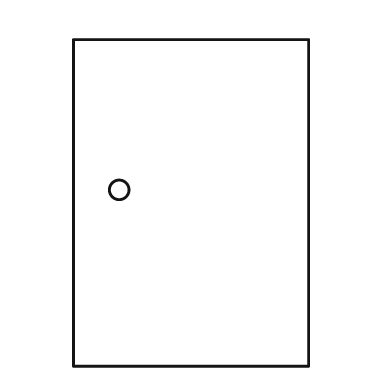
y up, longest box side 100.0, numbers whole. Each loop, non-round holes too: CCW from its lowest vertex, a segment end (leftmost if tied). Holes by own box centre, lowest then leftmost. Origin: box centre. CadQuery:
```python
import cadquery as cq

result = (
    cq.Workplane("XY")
    .moveTo(-36.0, -50.0)
    .lineTo(36.0, -50.0)
    .lineTo(36.0, 50.0)
    .lineTo(-36.0, 50.0)
    .close()
    .moveTo(-22.0, 4.0)
    .circle(3.0)
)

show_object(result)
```